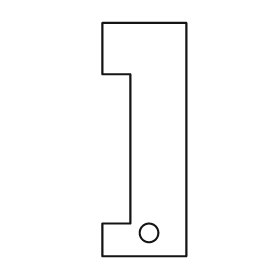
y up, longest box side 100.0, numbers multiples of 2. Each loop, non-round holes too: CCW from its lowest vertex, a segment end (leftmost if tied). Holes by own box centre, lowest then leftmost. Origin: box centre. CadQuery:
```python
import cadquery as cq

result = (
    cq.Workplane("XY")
    .moveTo(-18.0, -50.0)
    .lineTo(18.0, -50.0)
    .lineTo(18.0, 50.0)
    .lineTo(-18.0, 50.0)
    .lineTo(-18.0, 28.0)
    .lineTo(-6.0, 28.0)
    .lineTo(-6.0, -36.0)
    .lineTo(-18.0, -36.0)
    .close()
    .moveTo(2.0, -40.0)
    .circle(4.0)
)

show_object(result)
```